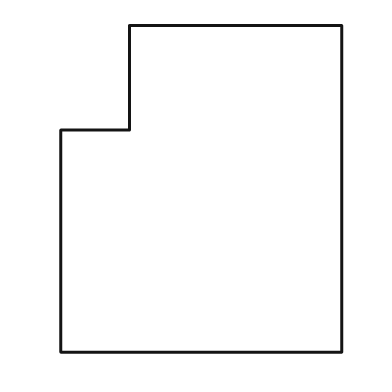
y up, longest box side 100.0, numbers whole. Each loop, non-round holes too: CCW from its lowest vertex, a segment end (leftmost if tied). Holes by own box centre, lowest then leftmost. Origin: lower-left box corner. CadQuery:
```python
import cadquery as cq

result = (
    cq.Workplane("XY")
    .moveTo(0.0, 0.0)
    .lineTo(86.0, 0.0)
    .lineTo(86.0, 100.0)
    .lineTo(21.0, 100.0)
    .lineTo(21.0, 68.0)
    .lineTo(0.0, 68.0)
    .close()
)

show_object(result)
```